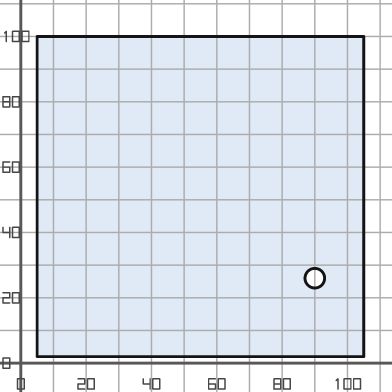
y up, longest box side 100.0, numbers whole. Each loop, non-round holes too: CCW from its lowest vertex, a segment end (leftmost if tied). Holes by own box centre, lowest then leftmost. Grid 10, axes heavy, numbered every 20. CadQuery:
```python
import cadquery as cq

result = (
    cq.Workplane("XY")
    .moveTo(5.0, 2.0)
    .lineTo(105.0, 2.0)
    .lineTo(105.0, 100.0)
    .lineTo(5.0, 100.0)
    .close()
    .moveTo(90.0, 26.0)
    .circle(3.0)
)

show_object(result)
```